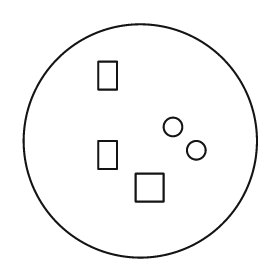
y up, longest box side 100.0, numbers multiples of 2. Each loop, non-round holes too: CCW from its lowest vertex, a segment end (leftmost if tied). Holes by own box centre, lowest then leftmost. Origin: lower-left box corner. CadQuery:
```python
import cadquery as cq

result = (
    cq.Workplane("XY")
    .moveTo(50.0, 50.0)
    .circle(50.0)
    .moveTo(48.0, 24.0)
    .lineTo(60.0, 24.0)
    .lineTo(60.0, 36.0)
    .lineTo(48.0, 36.0)
    .close()
    .moveTo(32.0, 38.0)
    .lineTo(40.0, 38.0)
    .lineTo(40.0, 50.0)
    .lineTo(32.0, 50.0)
    .close()
    .moveTo(74.0, 46.0)
    .circle(4.0)
    .moveTo(64.0, 56.0)
    .circle(4.0)
    .moveTo(32.0, 72.0)
    .lineTo(40.0, 72.0)
    .lineTo(40.0, 84.0)
    .lineTo(32.0, 84.0)
    .close()
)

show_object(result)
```